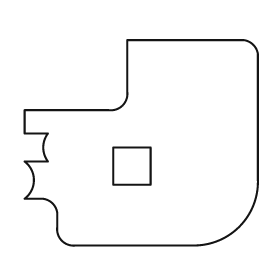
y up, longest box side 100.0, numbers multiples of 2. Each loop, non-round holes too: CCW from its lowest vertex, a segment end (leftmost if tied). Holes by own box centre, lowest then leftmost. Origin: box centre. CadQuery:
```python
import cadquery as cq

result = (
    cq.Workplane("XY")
    .moveTo(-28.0, -44.0)
    .lineTo(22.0, -44.0)
    .threePointArc((42.0, -36.0), (50.0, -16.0))
    .lineTo(50.0, 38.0)
    .threePointArc((48.0, 42.0), (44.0, 44.0))
    .lineTo(-6.0, 44.0)
    .lineTo(-6.0, 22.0)
    .threePointArc((-8.0, 16.0), (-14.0, 14.0))
    .lineTo(-50.0, 14.0)
    .lineTo(-50.0, 4.0)
    .lineTo(-40.0, 4.0)
    .threePointArc((-42.0, -2.0), (-40.0, -8.0))
    .lineTo(-50.0, -8.0)
    .threePointArc((-46.0, -16.0), (-50.0, -24.0))
    .lineTo(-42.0, -24.0)
    .threePointArc((-38.0, -26.0), (-36.0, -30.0))
    .lineTo(-36.0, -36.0)
    .threePointArc((-34.0, -42.0), (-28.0, -44.0))
    .close()
    .moveTo(-12.0, -18.0)
    .lineTo(4.0, -18.0)
    .lineTo(4.0, -2.0)
    .lineTo(-12.0, -2.0)
    .close()
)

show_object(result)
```